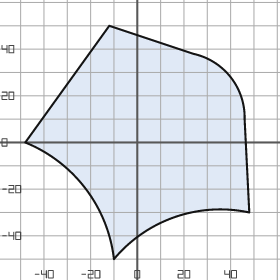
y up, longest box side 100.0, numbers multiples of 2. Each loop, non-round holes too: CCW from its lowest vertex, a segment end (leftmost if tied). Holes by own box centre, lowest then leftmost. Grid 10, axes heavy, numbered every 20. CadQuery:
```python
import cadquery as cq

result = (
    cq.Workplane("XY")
    .moveTo(-10.0, -50.0)
    .threePointArc((16.0, -32.0), (48.0, -30.0))
    .lineTo(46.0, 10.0)
    .threePointArc((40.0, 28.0), (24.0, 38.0))
    .lineTo(-12.0, 50.0)
    .lineTo(-48.0, 0.0)
    .threePointArc((-22.0, -20.0), (-10.0, -50.0))
    .close()
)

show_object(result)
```